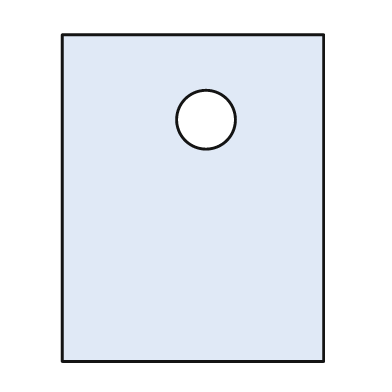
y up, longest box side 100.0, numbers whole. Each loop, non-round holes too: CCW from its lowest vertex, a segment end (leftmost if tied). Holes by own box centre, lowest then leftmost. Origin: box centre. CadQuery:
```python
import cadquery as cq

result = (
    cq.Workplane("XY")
    .moveTo(-40.0, -50.0)
    .lineTo(40.0, -50.0)
    .lineTo(40.0, 50.0)
    .lineTo(-40.0, 50.0)
    .close()
    .moveTo(4.0, 24.0)
    .circle(9.0)
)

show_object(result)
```